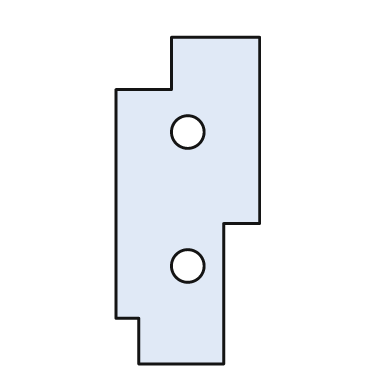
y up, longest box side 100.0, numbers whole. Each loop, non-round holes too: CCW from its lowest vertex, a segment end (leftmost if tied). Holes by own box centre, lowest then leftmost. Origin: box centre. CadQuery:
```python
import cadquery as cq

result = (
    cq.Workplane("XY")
    .moveTo(-15.0, -50.0)
    .lineTo(11.0, -50.0)
    .lineTo(11.0, -7.0)
    .lineTo(22.0, -7.0)
    .lineTo(22.0, 50.0)
    .lineTo(-5.0, 50.0)
    .lineTo(-5.0, 34.0)
    .lineTo(-22.0, 34.0)
    .lineTo(-22.0, -36.0)
    .lineTo(-15.0, -36.0)
    .close()
    .moveTo(0.0, -20.0)
    .circle(5.0)
    .moveTo(0.0, 21.0)
    .circle(5.0)
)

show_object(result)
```